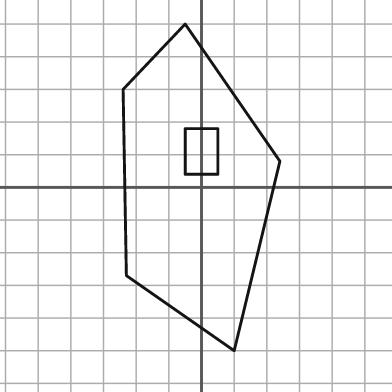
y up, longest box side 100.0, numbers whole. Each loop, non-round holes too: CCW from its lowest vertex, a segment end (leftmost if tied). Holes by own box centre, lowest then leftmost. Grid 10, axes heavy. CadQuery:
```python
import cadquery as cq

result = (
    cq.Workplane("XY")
    .moveTo(10.0, -50.0)
    .lineTo(24.0, 8.0)
    .lineTo(-5.0, 50.0)
    .lineTo(-24.0, 30.0)
    .lineTo(-23.0, -27.0)
    .close()
    .moveTo(-5.0, 4.0)
    .lineTo(5.0, 4.0)
    .lineTo(5.0, 18.0)
    .lineTo(-5.0, 18.0)
    .close()
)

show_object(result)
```